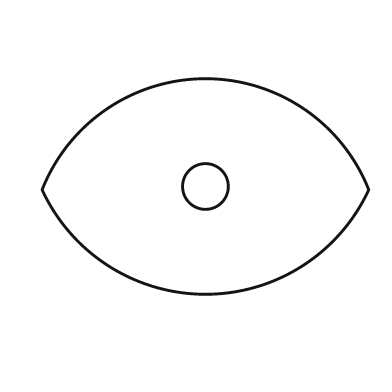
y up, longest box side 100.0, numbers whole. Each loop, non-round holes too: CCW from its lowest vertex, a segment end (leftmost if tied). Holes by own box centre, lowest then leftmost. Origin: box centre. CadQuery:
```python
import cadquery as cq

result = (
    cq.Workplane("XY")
    .moveTo(-50.0, -1.0)
    .threePointArc((0.0, -33.0), (50.0, -1.0))
    .threePointArc((0.0, 33.0), (-50.0, -1.0))
    .close()
    .moveTo(0.0, 0.0)
    .circle(7.0)
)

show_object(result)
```